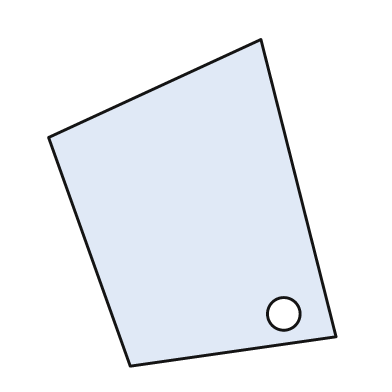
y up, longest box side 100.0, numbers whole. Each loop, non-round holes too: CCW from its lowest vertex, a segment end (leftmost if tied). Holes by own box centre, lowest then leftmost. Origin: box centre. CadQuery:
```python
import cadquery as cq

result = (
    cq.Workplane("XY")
    .moveTo(-19.0, -50.0)
    .lineTo(44.0, -41.0)
    .lineTo(21.0, 50.0)
    .lineTo(-44.0, 20.0)
    .close()
    .moveTo(28.0, -34.0)
    .circle(5.0)
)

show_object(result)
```